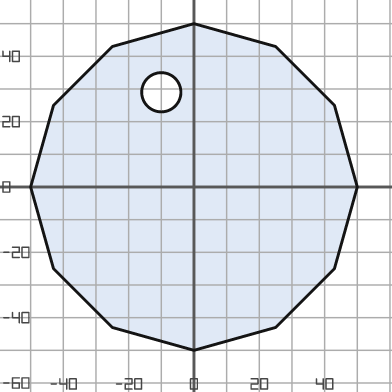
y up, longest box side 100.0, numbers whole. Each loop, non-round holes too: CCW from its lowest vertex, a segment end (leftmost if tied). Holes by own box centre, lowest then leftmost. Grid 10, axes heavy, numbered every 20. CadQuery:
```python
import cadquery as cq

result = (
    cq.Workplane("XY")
    .moveTo(0.0, -50.0)
    .lineTo(25.0, -43.0)
    .lineTo(43.0, -25.0)
    .lineTo(50.0, 0.0)
    .lineTo(43.0, 25.0)
    .lineTo(25.0, 43.0)
    .lineTo(0.0, 50.0)
    .lineTo(-25.0, 43.0)
    .lineTo(-43.0, 25.0)
    .lineTo(-50.0, 0.0)
    .lineTo(-43.0, -25.0)
    .lineTo(-25.0, -43.0)
    .close()
    .moveTo(-10.0, 29.0)
    .circle(6.0)
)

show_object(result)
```